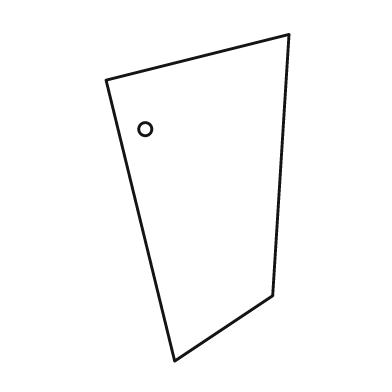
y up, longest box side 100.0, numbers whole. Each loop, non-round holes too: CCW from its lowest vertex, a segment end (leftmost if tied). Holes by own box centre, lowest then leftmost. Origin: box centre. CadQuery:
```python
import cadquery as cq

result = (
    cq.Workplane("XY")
    .moveTo(-7.0, -50.0)
    .lineTo(23.0, -30.0)
    .lineTo(28.0, 50.0)
    .lineTo(-28.0, 36.0)
    .close()
    .moveTo(-16.0, 21.0)
    .circle(2.0)
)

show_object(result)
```